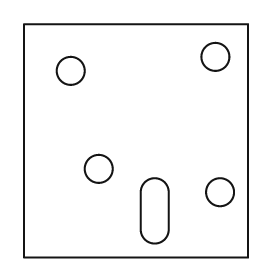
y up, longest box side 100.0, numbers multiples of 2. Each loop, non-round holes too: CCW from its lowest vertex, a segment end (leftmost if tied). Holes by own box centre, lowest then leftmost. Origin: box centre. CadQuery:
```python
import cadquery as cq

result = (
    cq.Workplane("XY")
    .moveTo(-48.0, -50.0)
    .lineTo(48.0, -50.0)
    .lineTo(48.0, 50.0)
    .lineTo(-48.0, 50.0)
    .close()
    .moveTo(2.0, -38.0)
    .threePointArc((8.0, -44.0), (14.0, -38.0))
    .lineTo(14.0, -22.0)
    .threePointArc((8.0, -16.0), (2.0, -22.0))
    .close()
    .moveTo(36.0, -22.0)
    .circle(6.0)
    .moveTo(-16.0, -12.0)
    .circle(6.0)
    .moveTo(-28.0, 30.0)
    .circle(6.0)
    .moveTo(34.0, 36.0)
    .circle(6.0)
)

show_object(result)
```